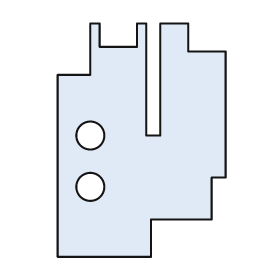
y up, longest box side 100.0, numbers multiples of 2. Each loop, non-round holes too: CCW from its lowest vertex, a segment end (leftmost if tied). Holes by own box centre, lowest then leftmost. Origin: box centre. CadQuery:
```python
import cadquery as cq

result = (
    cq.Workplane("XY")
    .moveTo(-36.0, -50.0)
    .lineTo(4.0, -50.0)
    .lineTo(4.0, -34.0)
    .lineTo(30.0, -34.0)
    .lineTo(30.0, -16.0)
    .lineTo(36.0, -16.0)
    .lineTo(36.0, 38.0)
    .lineTo(20.0, 38.0)
    .lineTo(20.0, 50.0)
    .lineTo(8.0, 50.0)
    .lineTo(8.0, 2.0)
    .lineTo(2.0, 2.0)
    .lineTo(2.0, 50.0)
    .lineTo(-2.0, 50.0)
    .lineTo(-2.0, 40.0)
    .lineTo(-18.0, 40.0)
    .lineTo(-18.0, 50.0)
    .lineTo(-22.0, 50.0)
    .lineTo(-22.0, 28.0)
    .lineTo(-36.0, 28.0)
    .close()
    .moveTo(-22.0, -20.0)
    .circle(6.0)
    .moveTo(-22.0, 2.0)
    .circle(6.0)
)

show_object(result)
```